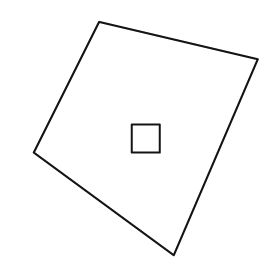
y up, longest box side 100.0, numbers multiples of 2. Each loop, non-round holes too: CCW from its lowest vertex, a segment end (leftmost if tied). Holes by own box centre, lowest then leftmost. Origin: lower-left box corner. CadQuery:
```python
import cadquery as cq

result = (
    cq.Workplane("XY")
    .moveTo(60.0, 0.0)
    .lineTo(96.0, 84.0)
    .lineTo(28.0, 100.0)
    .lineTo(0.0, 44.0)
    .close()
    .moveTo(42.0, 44.0)
    .lineTo(54.0, 44.0)
    .lineTo(54.0, 56.0)
    .lineTo(42.0, 56.0)
    .close()
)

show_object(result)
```